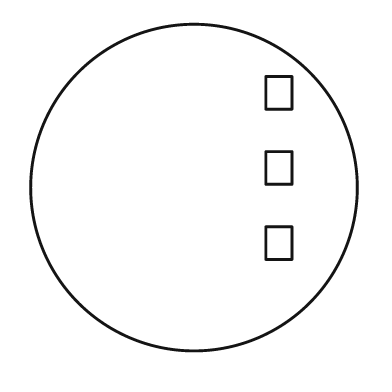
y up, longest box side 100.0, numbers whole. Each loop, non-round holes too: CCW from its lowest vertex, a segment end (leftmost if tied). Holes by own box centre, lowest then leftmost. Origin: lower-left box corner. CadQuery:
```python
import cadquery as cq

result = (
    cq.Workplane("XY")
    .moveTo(50.0, 50.0)
    .circle(50.0)
    .moveTo(72.0, 28.0)
    .lineTo(80.0, 28.0)
    .lineTo(80.0, 38.0)
    .lineTo(72.0, 38.0)
    .close()
    .moveTo(72.0, 51.0)
    .lineTo(80.0, 51.0)
    .lineTo(80.0, 61.0)
    .lineTo(72.0, 61.0)
    .close()
    .moveTo(72.0, 74.0)
    .lineTo(80.0, 74.0)
    .lineTo(80.0, 84.0)
    .lineTo(72.0, 84.0)
    .close()
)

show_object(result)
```